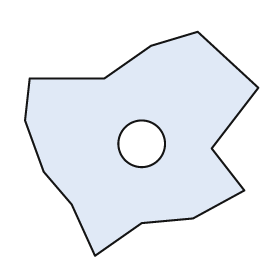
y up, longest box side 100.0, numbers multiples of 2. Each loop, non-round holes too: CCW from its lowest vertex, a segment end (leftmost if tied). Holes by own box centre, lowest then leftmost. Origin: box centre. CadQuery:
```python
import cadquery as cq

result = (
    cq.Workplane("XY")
    .moveTo(-20.0, -48.0)
    .lineTo(0.0, -34.0)
    .lineTo(22.0, -32.0)
    .lineTo(44.0, -20.0)
    .lineTo(30.0, -2.0)
    .lineTo(50.0, 24.0)
    .lineTo(24.0, 48.0)
    .lineTo(4.0, 42.0)
    .lineTo(-16.0, 28.0)
    .lineTo(-48.0, 28.0)
    .lineTo(-50.0, 10.0)
    .lineTo(-42.0, -12.0)
    .lineTo(-30.0, -26.0)
    .close()
    .moveTo(0.0, 0.0)
    .circle(10.0)
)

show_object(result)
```